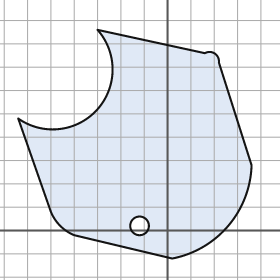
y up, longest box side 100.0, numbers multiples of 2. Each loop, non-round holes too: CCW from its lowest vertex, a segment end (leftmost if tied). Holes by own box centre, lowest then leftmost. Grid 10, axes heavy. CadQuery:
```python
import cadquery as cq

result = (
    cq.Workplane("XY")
    .moveTo(2.0, -12.0)
    .threePointArc((26.0, 2.0), (36.0, 28.0))
    .lineTo(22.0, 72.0)
    .threePointArc((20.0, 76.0), (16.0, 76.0))
    .lineTo(-30.0, 86.0)
    .threePointArc((-30.0, 52.0), (-64.0, 48.0))
    .lineTo(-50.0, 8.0)
    .threePointArc((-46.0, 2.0), (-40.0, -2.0))
    .close()
    .moveTo(-12.0, 2.0)
    .circle(4.0)
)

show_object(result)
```